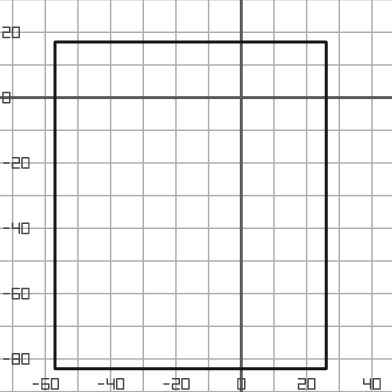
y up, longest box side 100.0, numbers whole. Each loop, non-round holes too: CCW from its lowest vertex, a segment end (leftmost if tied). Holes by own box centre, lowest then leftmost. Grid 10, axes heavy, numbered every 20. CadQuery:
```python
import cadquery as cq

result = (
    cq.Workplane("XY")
    .moveTo(-57.0, -83.0)
    .lineTo(26.0, -83.0)
    .lineTo(26.0, 17.0)
    .lineTo(-57.0, 17.0)
    .close()
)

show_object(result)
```